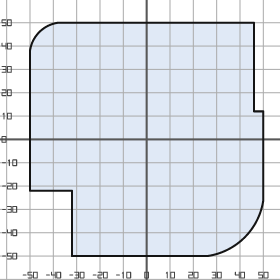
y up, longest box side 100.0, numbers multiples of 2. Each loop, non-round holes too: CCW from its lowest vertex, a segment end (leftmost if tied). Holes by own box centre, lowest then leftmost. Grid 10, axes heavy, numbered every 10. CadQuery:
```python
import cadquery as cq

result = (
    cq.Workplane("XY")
    .moveTo(-32.0, -50.0)
    .lineTo(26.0, -50.0)
    .threePointArc((42.0, -42.0), (50.0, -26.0))
    .lineTo(50.0, 12.0)
    .lineTo(46.0, 12.0)
    .lineTo(46.0, 50.0)
    .lineTo(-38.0, 50.0)
    .threePointArc((-46.0, 46.0), (-50.0, 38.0))
    .lineTo(-50.0, -22.0)
    .lineTo(-32.0, -22.0)
    .close()
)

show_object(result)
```